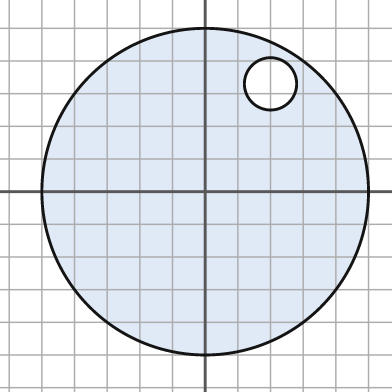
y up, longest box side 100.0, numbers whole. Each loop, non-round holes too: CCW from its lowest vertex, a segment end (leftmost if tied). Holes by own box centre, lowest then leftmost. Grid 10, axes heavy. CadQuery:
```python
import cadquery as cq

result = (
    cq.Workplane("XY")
    .moveTo(0.0, 0.0)
    .circle(50.0)
    .moveTo(20.0, 33.0)
    .circle(8.0)
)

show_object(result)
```